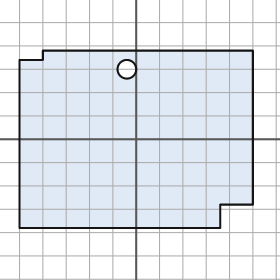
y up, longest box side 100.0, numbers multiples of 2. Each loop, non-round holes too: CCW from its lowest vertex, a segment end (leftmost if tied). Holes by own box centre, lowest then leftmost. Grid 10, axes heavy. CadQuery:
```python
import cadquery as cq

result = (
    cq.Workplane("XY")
    .moveTo(-50.0, -38.0)
    .lineTo(36.0, -38.0)
    .lineTo(36.0, -28.0)
    .lineTo(50.0, -28.0)
    .lineTo(50.0, 38.0)
    .lineTo(-40.0, 38.0)
    .lineTo(-40.0, 34.0)
    .lineTo(-50.0, 34.0)
    .close()
    .moveTo(-4.0, 30.0)
    .circle(4.0)
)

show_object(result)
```